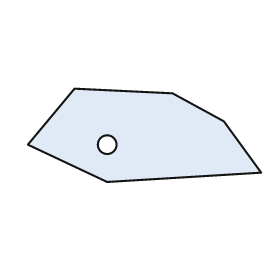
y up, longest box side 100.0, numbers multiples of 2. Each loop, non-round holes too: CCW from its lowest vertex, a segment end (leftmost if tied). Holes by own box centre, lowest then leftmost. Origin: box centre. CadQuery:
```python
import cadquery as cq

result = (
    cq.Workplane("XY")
    .moveTo(-16.0, -20.0)
    .lineTo(50.0, -16.0)
    .lineTo(34.0, 6.0)
    .lineTo(12.0, 18.0)
    .lineTo(-30.0, 20.0)
    .lineTo(-50.0, -4.0)
    .close()
    .moveTo(-16.0, -4.0)
    .circle(4.0)
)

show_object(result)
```